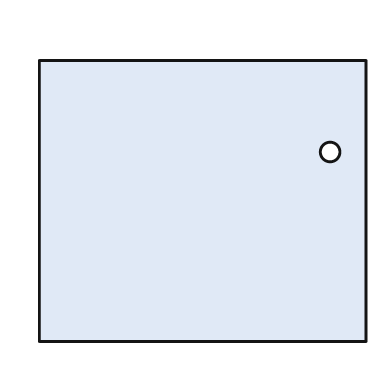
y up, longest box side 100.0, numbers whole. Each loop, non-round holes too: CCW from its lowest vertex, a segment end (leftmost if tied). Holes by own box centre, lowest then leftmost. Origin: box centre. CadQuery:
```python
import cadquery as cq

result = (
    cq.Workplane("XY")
    .moveTo(-50.0, -43.0)
    .lineTo(50.0, -43.0)
    .lineTo(50.0, 43.0)
    .lineTo(-50.0, 43.0)
    .close()
    .moveTo(39.0, 15.0)
    .circle(3.0)
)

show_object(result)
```